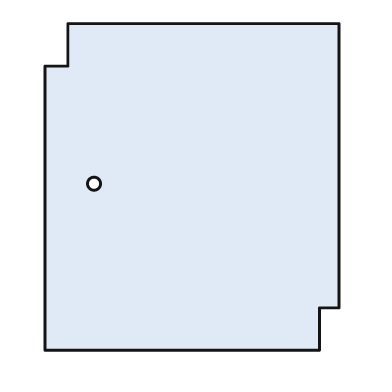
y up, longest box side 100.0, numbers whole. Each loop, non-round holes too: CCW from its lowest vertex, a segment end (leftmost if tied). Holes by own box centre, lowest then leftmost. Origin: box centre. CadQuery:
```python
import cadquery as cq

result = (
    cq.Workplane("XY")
    .moveTo(-45.0, -50.0)
    .lineTo(39.0, -50.0)
    .lineTo(39.0, -37.0)
    .lineTo(45.0, -37.0)
    .lineTo(45.0, 50.0)
    .lineTo(-38.0, 50.0)
    .lineTo(-38.0, 37.0)
    .lineTo(-45.0, 37.0)
    .close()
    .moveTo(-30.0, 1.0)
    .circle(2.0)
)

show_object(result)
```